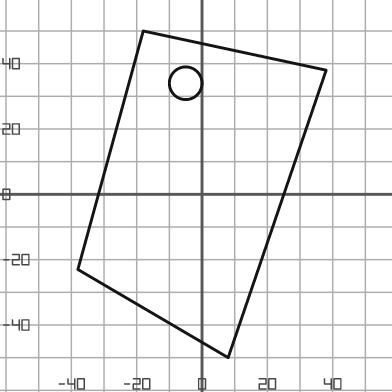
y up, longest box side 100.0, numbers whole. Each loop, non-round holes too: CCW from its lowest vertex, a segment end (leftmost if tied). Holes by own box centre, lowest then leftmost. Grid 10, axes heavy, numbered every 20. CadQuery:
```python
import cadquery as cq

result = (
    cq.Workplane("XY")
    .moveTo(8.0, -50.0)
    .lineTo(38.0, 38.0)
    .lineTo(-18.0, 50.0)
    .lineTo(-38.0, -23.0)
    .close()
    .moveTo(-5.0, 34.0)
    .circle(5.0)
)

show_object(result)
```